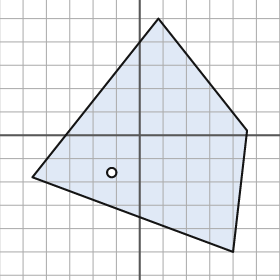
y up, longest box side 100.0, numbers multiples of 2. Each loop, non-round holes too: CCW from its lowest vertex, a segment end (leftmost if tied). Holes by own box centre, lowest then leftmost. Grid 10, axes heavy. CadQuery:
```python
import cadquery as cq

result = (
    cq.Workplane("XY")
    .moveTo(40.0, -50.0)
    .lineTo(46.0, 2.0)
    .lineTo(8.0, 50.0)
    .lineTo(-46.0, -18.0)
    .close()
    .moveTo(-12.0, -16.0)
    .circle(2.0)
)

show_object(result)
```